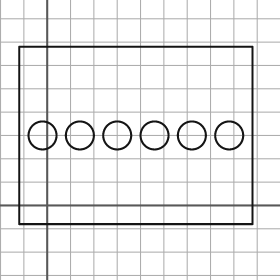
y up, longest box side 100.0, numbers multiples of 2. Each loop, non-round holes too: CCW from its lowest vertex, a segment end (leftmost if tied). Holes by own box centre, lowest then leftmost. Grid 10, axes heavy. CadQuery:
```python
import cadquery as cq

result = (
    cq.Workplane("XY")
    .moveTo(-12.0, -8.0)
    .lineTo(88.0, -8.0)
    .lineTo(88.0, 68.0)
    .lineTo(-12.0, 68.0)
    .close()
    .moveTo(-2.0, 30.0)
    .circle(6.0)
    .moveTo(14.0, 30.0)
    .circle(6.0)
    .moveTo(30.0, 30.0)
    .circle(6.0)
    .moveTo(46.0, 30.0)
    .circle(6.0)
    .moveTo(62.0, 30.0)
    .circle(6.0)
    .moveTo(78.0, 30.0)
    .circle(6.0)
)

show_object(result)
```